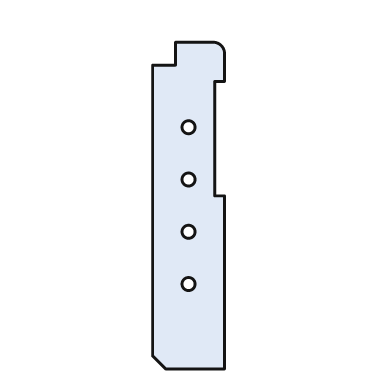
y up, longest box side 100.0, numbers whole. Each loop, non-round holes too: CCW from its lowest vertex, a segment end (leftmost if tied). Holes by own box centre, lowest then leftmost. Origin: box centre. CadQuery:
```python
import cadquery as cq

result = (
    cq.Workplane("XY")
    .moveTo(-7.0, -50.0)
    .lineTo(11.0, -50.0)
    .lineTo(11.0, 3.0)
    .lineTo(8.0, 3.0)
    .lineTo(8.0, 38.0)
    .lineTo(11.0, 38.0)
    .lineTo(11.0, 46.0)
    .threePointArc((10.0, 49.0), (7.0, 50.0))
    .lineTo(-4.0, 50.0)
    .lineTo(-4.0, 43.0)
    .lineTo(-11.0, 43.0)
    .lineTo(-11.0, -46.0)
    .close()
    .moveTo(0.0, -24.0)
    .circle(2.0)
    .moveTo(0.0, -8.0)
    .circle(2.0)
    .moveTo(0.0, 8.0)
    .circle(2.0)
    .moveTo(0.0, 24.0)
    .circle(2.0)
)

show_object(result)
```